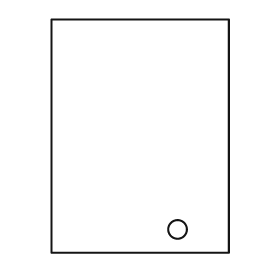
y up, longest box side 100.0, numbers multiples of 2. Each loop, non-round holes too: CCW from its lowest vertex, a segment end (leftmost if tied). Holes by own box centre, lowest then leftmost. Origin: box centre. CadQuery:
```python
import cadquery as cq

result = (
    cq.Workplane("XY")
    .moveTo(-38.0, -50.0)
    .lineTo(38.0, -50.0)
    .lineTo(38.0, 50.0)
    .lineTo(-38.0, 50.0)
    .close()
    .moveTo(16.0, -40.0)
    .circle(4.0)
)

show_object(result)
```